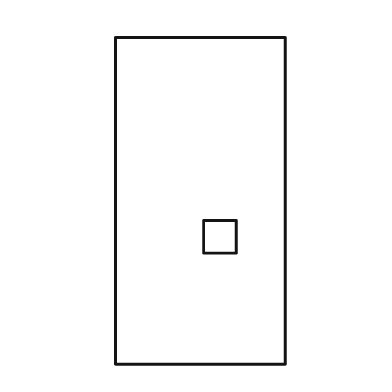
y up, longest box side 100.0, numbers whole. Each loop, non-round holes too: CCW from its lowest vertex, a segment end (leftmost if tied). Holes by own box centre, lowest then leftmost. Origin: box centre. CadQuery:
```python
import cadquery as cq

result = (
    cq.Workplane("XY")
    .moveTo(-26.0, -50.0)
    .lineTo(26.0, -50.0)
    .lineTo(26.0, 50.0)
    .lineTo(-26.0, 50.0)
    .close()
    .moveTo(1.0, -16.0)
    .lineTo(11.0, -16.0)
    .lineTo(11.0, -6.0)
    .lineTo(1.0, -6.0)
    .close()
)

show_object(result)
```